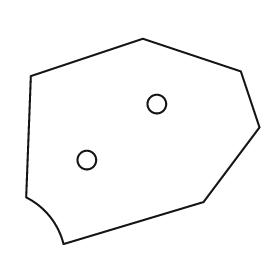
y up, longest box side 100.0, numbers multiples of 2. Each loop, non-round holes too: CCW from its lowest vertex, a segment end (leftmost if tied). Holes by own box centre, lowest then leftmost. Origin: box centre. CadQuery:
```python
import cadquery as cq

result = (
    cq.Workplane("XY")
    .moveTo(-34.0, -44.0)
    .lineTo(26.0, -26.0)
    .lineTo(50.0, 6.0)
    .lineTo(42.0, 30.0)
    .lineTo(0.0, 44.0)
    .lineTo(-48.0, 28.0)
    .lineTo(-50.0, -24.0)
    .threePointArc((-40.0, -32.0), (-34.0, -44.0))
    .close()
    .moveTo(-24.0, -8.0)
    .circle(4.0)
    .moveTo(6.0, 16.0)
    .circle(4.0)
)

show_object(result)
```